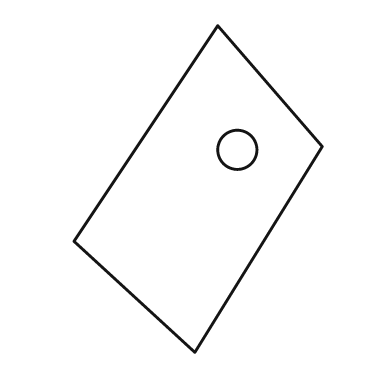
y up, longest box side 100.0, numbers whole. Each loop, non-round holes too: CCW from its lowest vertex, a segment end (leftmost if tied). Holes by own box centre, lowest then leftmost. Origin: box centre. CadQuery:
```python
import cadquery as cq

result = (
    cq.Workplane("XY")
    .moveTo(-1.0, -50.0)
    .lineTo(38.0, 13.0)
    .lineTo(6.0, 50.0)
    .lineTo(-38.0, -16.0)
    .close()
    .moveTo(12.0, 12.0)
    .circle(6.0)
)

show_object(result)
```